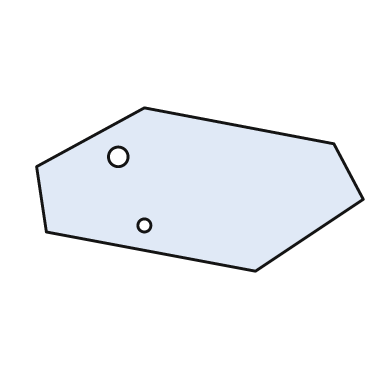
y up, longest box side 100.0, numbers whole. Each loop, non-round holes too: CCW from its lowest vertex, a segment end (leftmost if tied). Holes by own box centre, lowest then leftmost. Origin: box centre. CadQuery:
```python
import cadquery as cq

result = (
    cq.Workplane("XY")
    .moveTo(17.0, -25.0)
    .lineTo(50.0, -3.0)
    .lineTo(41.0, 14.0)
    .lineTo(-17.0, 25.0)
    .lineTo(-50.0, 7.0)
    .lineTo(-47.0, -13.0)
    .close()
    .moveTo(-17.0, -11.0)
    .circle(2.0)
    .moveTo(-25.0, 10.0)
    .circle(3.0)
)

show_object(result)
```